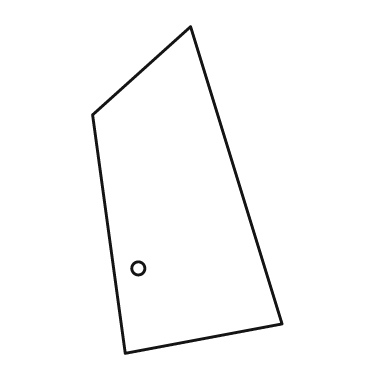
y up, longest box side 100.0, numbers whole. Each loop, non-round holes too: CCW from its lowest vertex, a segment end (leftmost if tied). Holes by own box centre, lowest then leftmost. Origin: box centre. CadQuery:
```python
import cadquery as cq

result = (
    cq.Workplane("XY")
    .moveTo(-19.0, -50.0)
    .lineTo(29.0, -41.0)
    .lineTo(1.0, 50.0)
    .lineTo(-29.0, 23.0)
    .close()
    .moveTo(-15.0, -24.0)
    .circle(2.0)
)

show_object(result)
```